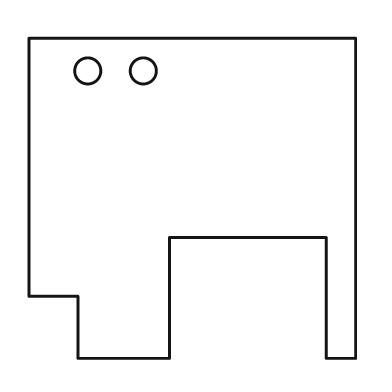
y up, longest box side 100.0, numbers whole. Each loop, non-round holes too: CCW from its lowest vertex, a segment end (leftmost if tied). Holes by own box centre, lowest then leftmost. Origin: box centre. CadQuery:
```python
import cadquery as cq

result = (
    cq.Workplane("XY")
    .moveTo(-35.0, -49.0)
    .lineTo(-7.0, -49.0)
    .lineTo(-7.0, -12.0)
    .lineTo(41.0, -12.0)
    .lineTo(41.0, -49.0)
    .lineTo(50.0, -49.0)
    .lineTo(50.0, 49.0)
    .lineTo(-50.0, 49.0)
    .lineTo(-50.0, -30.0)
    .lineTo(-35.0, -30.0)
    .close()
    .moveTo(-32.0, 39.0)
    .circle(4.0)
    .moveTo(-15.0, 39.0)
    .circle(4.0)
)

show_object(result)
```